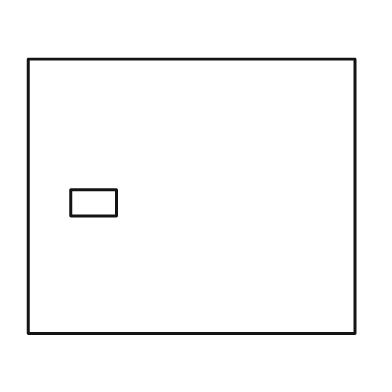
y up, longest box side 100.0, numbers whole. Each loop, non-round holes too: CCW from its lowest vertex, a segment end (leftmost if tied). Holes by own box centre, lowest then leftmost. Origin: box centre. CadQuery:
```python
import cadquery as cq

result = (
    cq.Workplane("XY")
    .moveTo(-50.0, -42.0)
    .lineTo(50.0, -42.0)
    .lineTo(50.0, 42.0)
    .lineTo(-50.0, 42.0)
    .close()
    .moveTo(-37.0, -6.0)
    .lineTo(-23.0, -6.0)
    .lineTo(-23.0, 2.0)
    .lineTo(-37.0, 2.0)
    .close()
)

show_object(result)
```